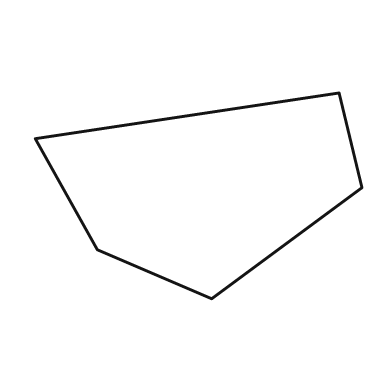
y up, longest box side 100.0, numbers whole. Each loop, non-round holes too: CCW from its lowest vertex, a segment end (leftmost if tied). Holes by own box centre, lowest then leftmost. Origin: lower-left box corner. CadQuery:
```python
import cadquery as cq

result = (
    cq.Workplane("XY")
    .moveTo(54.0, 0.0)
    .lineTo(100.0, 34.0)
    .lineTo(93.0, 63.0)
    .lineTo(0.0, 49.0)
    .lineTo(19.0, 15.0)
    .close()
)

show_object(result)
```